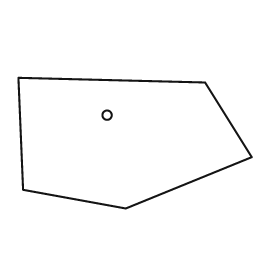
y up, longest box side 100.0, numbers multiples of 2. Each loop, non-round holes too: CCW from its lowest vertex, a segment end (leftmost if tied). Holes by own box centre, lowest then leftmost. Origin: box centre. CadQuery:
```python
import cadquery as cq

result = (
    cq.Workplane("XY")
    .moveTo(-4.0, -28.0)
    .lineTo(50.0, -6.0)
    .lineTo(30.0, 26.0)
    .lineTo(-50.0, 28.0)
    .lineTo(-48.0, -20.0)
    .close()
    .moveTo(-12.0, 12.0)
    .circle(2.0)
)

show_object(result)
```